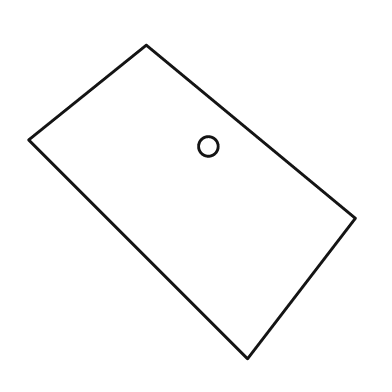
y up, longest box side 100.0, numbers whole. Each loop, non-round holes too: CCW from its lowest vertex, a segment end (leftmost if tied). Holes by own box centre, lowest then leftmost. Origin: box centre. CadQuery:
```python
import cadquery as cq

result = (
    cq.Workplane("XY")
    .moveTo(17.0, -48.0)
    .lineTo(50.0, -5.0)
    .lineTo(-14.0, 48.0)
    .lineTo(-50.0, 19.0)
    .close()
    .moveTo(5.0, 17.0)
    .circle(3.0)
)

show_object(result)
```